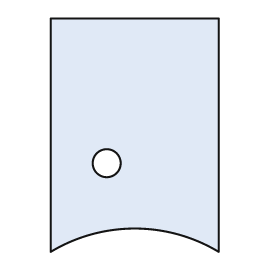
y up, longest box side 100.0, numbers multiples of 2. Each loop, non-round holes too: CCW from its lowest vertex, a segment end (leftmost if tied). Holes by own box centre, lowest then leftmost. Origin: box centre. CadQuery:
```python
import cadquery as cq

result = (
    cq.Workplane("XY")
    .moveTo(-36.0, -50.0)
    .threePointArc((0.0, -40.0), (36.0, -50.0))
    .lineTo(36.0, 50.0)
    .lineTo(-36.0, 50.0)
    .close()
    .moveTo(-12.0, -12.0)
    .circle(6.0)
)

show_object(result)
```